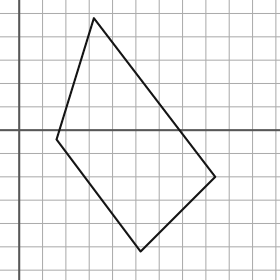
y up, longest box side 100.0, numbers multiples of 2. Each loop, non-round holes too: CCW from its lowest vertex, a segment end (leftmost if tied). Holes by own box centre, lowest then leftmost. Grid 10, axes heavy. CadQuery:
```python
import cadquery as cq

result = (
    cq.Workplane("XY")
    .moveTo(52.0, -52.0)
    .lineTo(84.0, -20.0)
    .lineTo(32.0, 48.0)
    .lineTo(16.0, -4.0)
    .close()
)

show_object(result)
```